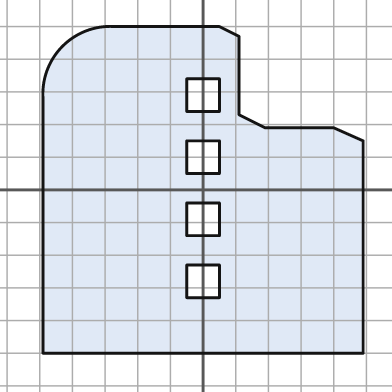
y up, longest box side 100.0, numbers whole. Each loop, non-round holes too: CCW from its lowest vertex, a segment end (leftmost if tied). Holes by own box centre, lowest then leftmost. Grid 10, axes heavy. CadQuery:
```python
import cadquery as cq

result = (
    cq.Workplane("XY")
    .moveTo(-49.0, -50.0)
    .lineTo(49.0, -50.0)
    .lineTo(49.0, 15.0)
    .lineTo(40.0, 19.0)
    .lineTo(19.0, 19.0)
    .lineTo(11.0, 23.0)
    .lineTo(11.0, 47.0)
    .lineTo(5.0, 50.0)
    .lineTo(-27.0, 50.0)
    .threePointArc((-43.0, 44.0), (-49.0, 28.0))
    .close()
    .moveTo(-5.0, -33.0)
    .lineTo(5.0, -33.0)
    .lineTo(5.0, -23.0)
    .lineTo(-5.0, -23.0)
    .close()
    .moveTo(-5.0, -14.0)
    .lineTo(5.0, -14.0)
    .lineTo(5.0, -4.0)
    .lineTo(-5.0, -4.0)
    .close()
    .moveTo(-5.0, 5.0)
    .lineTo(5.0, 5.0)
    .lineTo(5.0, 15.0)
    .lineTo(-5.0, 15.0)
    .close()
    .moveTo(-5.0, 24.0)
    .lineTo(5.0, 24.0)
    .lineTo(5.0, 34.0)
    .lineTo(-5.0, 34.0)
    .close()
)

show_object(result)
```